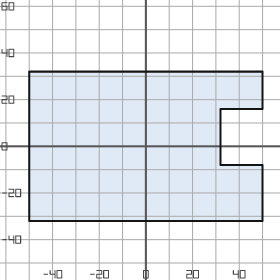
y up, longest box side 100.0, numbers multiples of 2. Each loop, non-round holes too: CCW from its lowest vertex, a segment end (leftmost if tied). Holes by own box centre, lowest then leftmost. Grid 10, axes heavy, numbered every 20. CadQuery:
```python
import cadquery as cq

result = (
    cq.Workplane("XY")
    .moveTo(-50.0, -32.0)
    .lineTo(50.0, -32.0)
    .lineTo(50.0, -8.0)
    .lineTo(32.0, -8.0)
    .lineTo(32.0, 16.0)
    .lineTo(50.0, 16.0)
    .lineTo(50.0, 32.0)
    .lineTo(-50.0, 32.0)
    .close()
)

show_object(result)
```